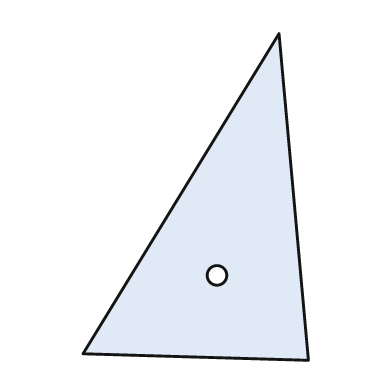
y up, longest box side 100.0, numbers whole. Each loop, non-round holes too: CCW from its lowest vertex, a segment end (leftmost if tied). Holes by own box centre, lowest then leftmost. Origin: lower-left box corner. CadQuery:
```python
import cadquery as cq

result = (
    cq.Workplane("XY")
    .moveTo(69.0, 0.0)
    .lineTo(60.0, 100.0)
    .lineTo(0.0, 2.0)
    .close()
    .moveTo(41.0, 26.0)
    .circle(3.0)
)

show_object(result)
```